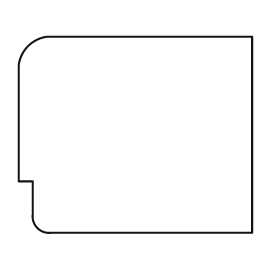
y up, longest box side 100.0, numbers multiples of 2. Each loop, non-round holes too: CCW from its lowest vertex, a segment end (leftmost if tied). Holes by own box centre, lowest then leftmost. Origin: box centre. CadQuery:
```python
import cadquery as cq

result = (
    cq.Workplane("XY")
    .moveTo(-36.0, -42.0)
    .lineTo(50.0, -42.0)
    .lineTo(50.0, 42.0)
    .lineTo(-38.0, 42.0)
    .threePointArc((-46.0, 38.0), (-50.0, 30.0))
    .lineTo(-50.0, -20.0)
    .lineTo(-44.0, -20.0)
    .lineTo(-44.0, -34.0)
    .threePointArc((-42.0, -40.0), (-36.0, -42.0))
    .close()
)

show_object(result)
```